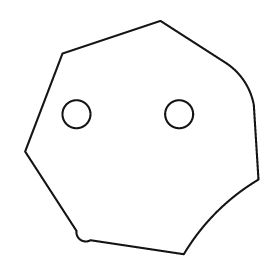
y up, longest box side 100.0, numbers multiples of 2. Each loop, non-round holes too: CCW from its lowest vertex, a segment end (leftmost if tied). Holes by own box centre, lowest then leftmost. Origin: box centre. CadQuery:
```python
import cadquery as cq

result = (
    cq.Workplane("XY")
    .moveTo(18.0, -50.0)
    .threePointArc((32.0, -32.0), (50.0, -18.0))
    .lineTo(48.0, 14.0)
    .threePointArc((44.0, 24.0), (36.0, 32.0))
    .lineTo(8.0, 50.0)
    .lineTo(-34.0, 36.0)
    .lineTo(-50.0, -6.0)
    .lineTo(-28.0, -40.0)
    .threePointArc((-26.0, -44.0), (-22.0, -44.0))
    .close()
    .moveTo(-28.0, 10.0)
    .circle(6.0)
    .moveTo(16.0, 10.0)
    .circle(6.0)
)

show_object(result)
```